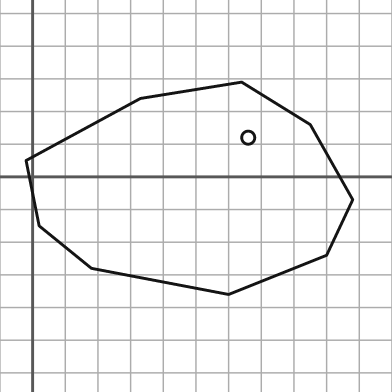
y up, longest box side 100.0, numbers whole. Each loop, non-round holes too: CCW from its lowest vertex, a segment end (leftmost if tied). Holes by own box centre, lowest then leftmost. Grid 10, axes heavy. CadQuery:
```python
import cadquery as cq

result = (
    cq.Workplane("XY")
    .moveTo(60.0, -36.0)
    .lineTo(90.0, -24.0)
    .lineTo(98.0, -7.0)
    .lineTo(85.0, 16.0)
    .lineTo(64.0, 29.0)
    .lineTo(33.0, 24.0)
    .lineTo(-2.0, 5.0)
    .lineTo(2.0, -15.0)
    .lineTo(18.0, -28.0)
    .close()
    .moveTo(66.0, 12.0)
    .circle(2.0)
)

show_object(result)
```